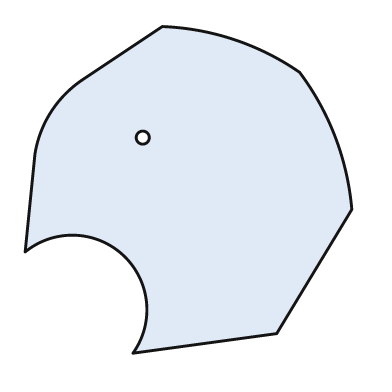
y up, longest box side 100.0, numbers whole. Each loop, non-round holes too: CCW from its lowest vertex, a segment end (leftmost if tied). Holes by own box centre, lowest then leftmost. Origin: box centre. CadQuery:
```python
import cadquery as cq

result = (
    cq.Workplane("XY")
    .moveTo(-17.0, -50.0)
    .lineTo(27.0, -44.0)
    .lineTo(50.0, -6.0)
    .threePointArc((45.0, 16.0), (34.0, 36.0))
    .threePointArc((14.0, 46.0), (-8.0, 50.0))
    .lineTo(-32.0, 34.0)
    .threePointArc((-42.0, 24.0), (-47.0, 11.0))
    .lineTo(-50.0, -19.0)
    .threePointArc((-20.0, -20.0), (-17.0, -50.0))
    .close()
    .moveTo(-14.0, 16.0)
    .circle(2.0)
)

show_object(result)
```